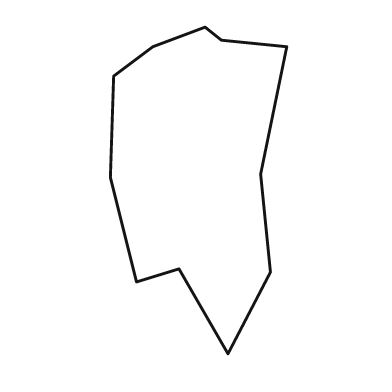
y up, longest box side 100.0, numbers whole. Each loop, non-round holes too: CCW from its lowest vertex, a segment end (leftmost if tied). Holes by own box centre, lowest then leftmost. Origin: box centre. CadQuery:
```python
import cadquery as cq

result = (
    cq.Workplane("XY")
    .moveTo(9.0, -50.0)
    .lineTo(22.0, -25.0)
    .lineTo(19.0, 5.0)
    .lineTo(27.0, 44.0)
    .lineTo(7.0, 46.0)
    .lineTo(2.0, 50.0)
    .lineTo(-14.0, 44.0)
    .lineTo(-26.0, 35.0)
    .lineTo(-27.0, 4.0)
    .lineTo(-19.0, -28.0)
    .lineTo(-6.0, -24.0)
    .close()
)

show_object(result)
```